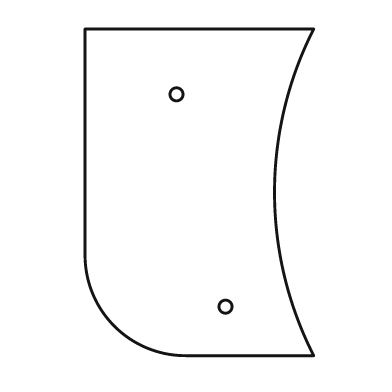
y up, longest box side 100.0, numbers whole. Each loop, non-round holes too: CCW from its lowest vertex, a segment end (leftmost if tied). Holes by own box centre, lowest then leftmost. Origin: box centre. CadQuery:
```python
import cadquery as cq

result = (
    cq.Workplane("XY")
    .moveTo(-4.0, -50.0)
    .lineTo(35.0, -50.0)
    .threePointArc((23.0, 0.0), (35.0, 50.0))
    .lineTo(-35.0, 50.0)
    .lineTo(-35.0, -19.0)
    .threePointArc((-26.0, -41.0), (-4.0, -50.0))
    .close()
    .moveTo(8.0, -35.0)
    .circle(2.0)
    .moveTo(-7.0, 30.0)
    .circle(2.0)
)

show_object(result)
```